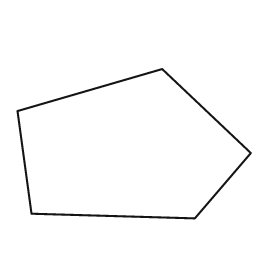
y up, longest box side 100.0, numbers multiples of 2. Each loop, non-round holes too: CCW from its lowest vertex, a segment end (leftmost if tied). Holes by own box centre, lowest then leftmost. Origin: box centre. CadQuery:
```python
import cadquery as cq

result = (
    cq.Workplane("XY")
    .moveTo(26.0, -32.0)
    .lineTo(50.0, -4.0)
    .lineTo(12.0, 32.0)
    .lineTo(-50.0, 14.0)
    .lineTo(-44.0, -30.0)
    .close()
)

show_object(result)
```